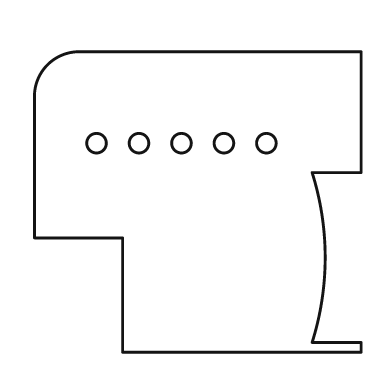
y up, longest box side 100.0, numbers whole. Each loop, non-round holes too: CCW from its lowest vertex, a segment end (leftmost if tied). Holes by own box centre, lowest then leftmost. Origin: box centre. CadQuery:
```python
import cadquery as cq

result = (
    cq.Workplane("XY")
    .moveTo(-23.0, -46.0)
    .lineTo(50.0, -46.0)
    .lineTo(50.0, -43.0)
    .lineTo(35.0, -43.0)
    .threePointArc((39.0, -17.0), (35.0, 9.0))
    .lineTo(50.0, 9.0)
    .lineTo(50.0, 46.0)
    .lineTo(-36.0, 46.0)
    .threePointArc((-46.0, 42.0), (-50.0, 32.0))
    .lineTo(-50.0, -11.0)
    .lineTo(-23.0, -11.0)
    .close()
    .moveTo(-31.0, 18.0)
    .circle(3.0)
    .moveTo(-18.0, 18.0)
    .circle(3.0)
    .moveTo(-5.0, 18.0)
    .circle(3.0)
    .moveTo(8.0, 18.0)
    .circle(3.0)
    .moveTo(21.0, 18.0)
    .circle(3.0)
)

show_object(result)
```